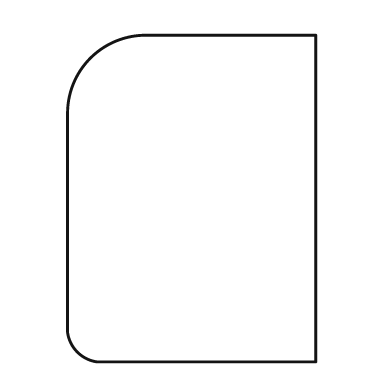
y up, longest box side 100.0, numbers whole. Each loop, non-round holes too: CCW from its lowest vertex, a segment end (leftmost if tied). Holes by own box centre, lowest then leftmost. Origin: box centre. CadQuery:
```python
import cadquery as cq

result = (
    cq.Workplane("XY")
    .moveTo(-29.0, -50.0)
    .lineTo(38.0, -50.0)
    .lineTo(38.0, 50.0)
    .lineTo(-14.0, 50.0)
    .threePointArc((-31.0, 43.0), (-38.0, 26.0))
    .lineTo(-38.0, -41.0)
    .threePointArc((-35.0, -47.0), (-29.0, -50.0))
    .close()
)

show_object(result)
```